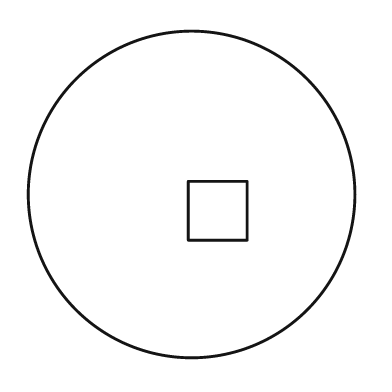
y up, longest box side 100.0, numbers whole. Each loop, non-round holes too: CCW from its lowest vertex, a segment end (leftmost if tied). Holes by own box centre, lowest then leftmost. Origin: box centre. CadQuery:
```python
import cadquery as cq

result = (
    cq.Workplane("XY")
    .moveTo(0.0, 0.0)
    .circle(50.0)
    .moveTo(-1.0, -14.0)
    .lineTo(17.0, -14.0)
    .lineTo(17.0, 4.0)
    .lineTo(-1.0, 4.0)
    .close()
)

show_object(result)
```